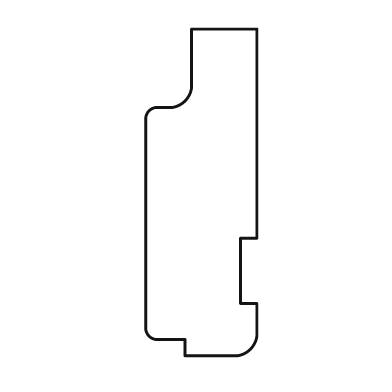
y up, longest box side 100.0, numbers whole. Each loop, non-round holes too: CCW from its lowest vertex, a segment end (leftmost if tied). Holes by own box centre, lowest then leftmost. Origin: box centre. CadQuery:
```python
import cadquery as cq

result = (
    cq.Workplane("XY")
    .moveTo(-5.0, -50.0)
    .lineTo(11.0, -50.0)
    .threePointArc((15.0, -48.0), (17.0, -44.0))
    .lineTo(17.0, -34.0)
    .lineTo(12.0, -34.0)
    .lineTo(12.0, -14.0)
    .lineTo(17.0, -14.0)
    .lineTo(17.0, 50.0)
    .lineTo(-3.0, 50.0)
    .lineTo(-3.0, 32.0)
    .threePointArc((-5.0, 28.0), (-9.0, 26.0))
    .lineTo(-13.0, 26.0)
    .threePointArc((-16.0, 25.0), (-17.0, 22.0))
    .lineTo(-17.0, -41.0)
    .threePointArc((-16.0, -44.0), (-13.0, -45.0))
    .lineTo(-5.0, -45.0)
    .close()
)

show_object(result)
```